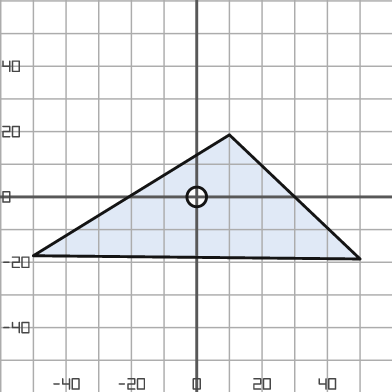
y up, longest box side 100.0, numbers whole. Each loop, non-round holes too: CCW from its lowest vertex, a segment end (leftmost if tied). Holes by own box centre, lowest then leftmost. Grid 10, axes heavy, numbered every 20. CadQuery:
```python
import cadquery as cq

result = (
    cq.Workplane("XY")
    .moveTo(50.0, -19.0)
    .lineTo(10.0, 19.0)
    .lineTo(-50.0, -18.0)
    .close()
    .moveTo(0.0, 0.0)
    .circle(3.0)
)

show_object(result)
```